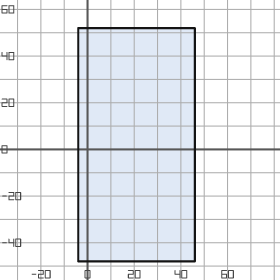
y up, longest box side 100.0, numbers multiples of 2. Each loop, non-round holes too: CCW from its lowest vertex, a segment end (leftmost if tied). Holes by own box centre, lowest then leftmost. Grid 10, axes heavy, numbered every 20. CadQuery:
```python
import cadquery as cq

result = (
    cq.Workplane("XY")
    .moveTo(-4.0, -48.0)
    .lineTo(46.0, -48.0)
    .lineTo(46.0, 52.0)
    .lineTo(-4.0, 52.0)
    .close()
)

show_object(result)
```